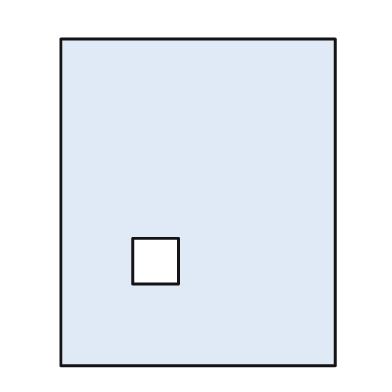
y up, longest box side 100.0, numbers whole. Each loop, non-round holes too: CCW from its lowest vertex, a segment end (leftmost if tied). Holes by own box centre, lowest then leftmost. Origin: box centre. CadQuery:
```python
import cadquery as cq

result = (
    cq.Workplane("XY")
    .moveTo(-42.0, -50.0)
    .lineTo(42.0, -50.0)
    .lineTo(42.0, 50.0)
    .lineTo(-42.0, 50.0)
    .close()
    .moveTo(-20.0, -25.0)
    .lineTo(-6.0, -25.0)
    .lineTo(-6.0, -11.0)
    .lineTo(-20.0, -11.0)
    .close()
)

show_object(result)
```